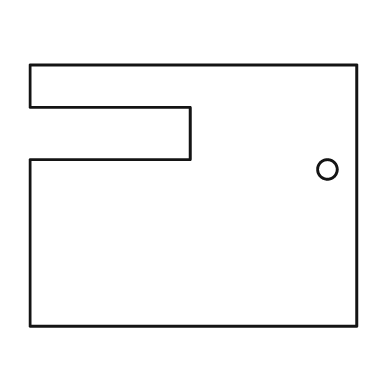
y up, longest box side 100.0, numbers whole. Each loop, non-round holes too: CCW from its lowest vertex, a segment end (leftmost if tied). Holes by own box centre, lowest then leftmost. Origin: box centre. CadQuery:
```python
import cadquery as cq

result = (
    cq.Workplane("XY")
    .moveTo(-50.0, -40.0)
    .lineTo(50.0, -40.0)
    .lineTo(50.0, 40.0)
    .lineTo(-50.0, 40.0)
    .lineTo(-50.0, 27.0)
    .lineTo(-1.0, 27.0)
    .lineTo(-1.0, 11.0)
    .lineTo(-50.0, 11.0)
    .close()
    .moveTo(41.0, 8.0)
    .circle(3.0)
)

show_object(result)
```